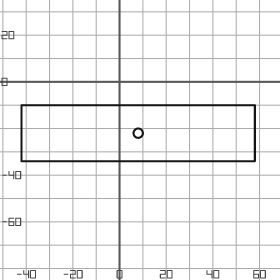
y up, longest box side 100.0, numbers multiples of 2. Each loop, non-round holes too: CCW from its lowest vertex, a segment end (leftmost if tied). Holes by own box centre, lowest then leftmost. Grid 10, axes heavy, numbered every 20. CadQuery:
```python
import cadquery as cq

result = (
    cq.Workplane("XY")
    .moveTo(-42.0, -34.0)
    .lineTo(58.0, -34.0)
    .lineTo(58.0, -10.0)
    .lineTo(-42.0, -10.0)
    .close()
    .moveTo(8.0, -22.0)
    .circle(2.0)
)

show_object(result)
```